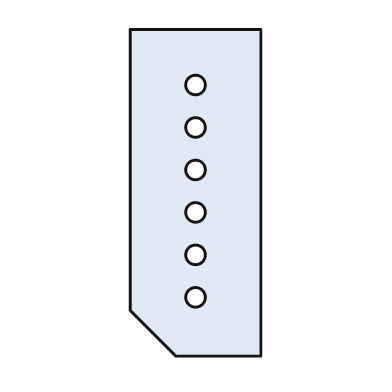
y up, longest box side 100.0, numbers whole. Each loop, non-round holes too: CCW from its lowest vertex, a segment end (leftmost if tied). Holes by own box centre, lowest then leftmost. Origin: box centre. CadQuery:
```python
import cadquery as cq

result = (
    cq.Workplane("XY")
    .moveTo(-6.0, -50.0)
    .lineTo(20.0, -50.0)
    .lineTo(20.0, 50.0)
    .lineTo(-20.0, 50.0)
    .lineTo(-20.0, -36.0)
    .close()
    .moveTo(0.0, -32.0)
    .circle(3.0)
    .moveTo(0.0, -19.0)
    .circle(3.0)
    .moveTo(0.0, -6.0)
    .circle(3.0)
    .moveTo(0.0, 7.0)
    .circle(3.0)
    .moveTo(0.0, 20.0)
    .circle(3.0)
    .moveTo(0.0, 33.0)
    .circle(3.0)
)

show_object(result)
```